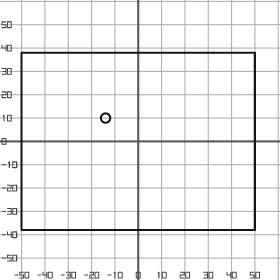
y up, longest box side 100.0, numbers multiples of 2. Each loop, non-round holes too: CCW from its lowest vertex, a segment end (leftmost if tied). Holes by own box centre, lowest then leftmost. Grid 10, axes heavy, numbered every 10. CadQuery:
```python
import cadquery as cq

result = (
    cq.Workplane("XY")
    .moveTo(-50.0, -38.0)
    .lineTo(50.0, -38.0)
    .lineTo(50.0, 38.0)
    .lineTo(-50.0, 38.0)
    .close()
    .moveTo(-14.0, 10.0)
    .circle(2.0)
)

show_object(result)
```